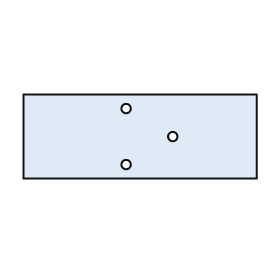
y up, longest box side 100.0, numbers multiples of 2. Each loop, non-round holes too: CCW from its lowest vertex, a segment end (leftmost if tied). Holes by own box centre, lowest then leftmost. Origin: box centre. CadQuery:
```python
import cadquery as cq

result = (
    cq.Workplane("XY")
    .moveTo(-50.0, -18.0)
    .lineTo(50.0, -18.0)
    .lineTo(50.0, 18.0)
    .lineTo(-50.0, 18.0)
    .close()
    .moveTo(-6.0, -12.0)
    .circle(2.0)
    .moveTo(14.0, 0.0)
    .circle(2.0)
    .moveTo(-6.0, 12.0)
    .circle(2.0)
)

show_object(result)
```